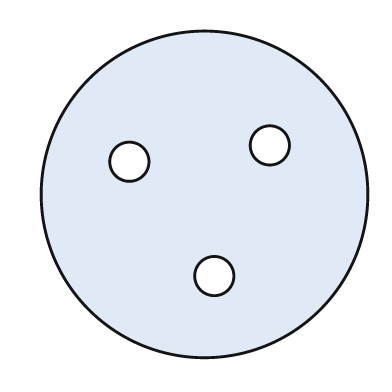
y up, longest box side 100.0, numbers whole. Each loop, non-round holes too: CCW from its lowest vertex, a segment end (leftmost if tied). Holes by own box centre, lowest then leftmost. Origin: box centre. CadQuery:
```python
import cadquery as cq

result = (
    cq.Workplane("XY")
    .moveTo(0.0, 0.0)
    .circle(50.0)
    .moveTo(3.0, -25.0)
    .circle(6.0)
    .moveTo(-23.0, 10.0)
    .circle(6.0)
    .moveTo(20.0, 15.0)
    .circle(6.0)
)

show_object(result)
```